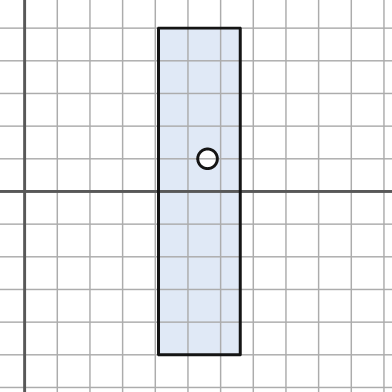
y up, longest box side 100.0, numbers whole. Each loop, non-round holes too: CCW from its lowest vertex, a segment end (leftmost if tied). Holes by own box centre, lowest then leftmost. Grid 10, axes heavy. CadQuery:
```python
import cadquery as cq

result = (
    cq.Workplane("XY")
    .moveTo(41.0, -50.0)
    .lineTo(66.0, -50.0)
    .lineTo(66.0, 50.0)
    .lineTo(41.0, 50.0)
    .close()
    .moveTo(56.0, 10.0)
    .circle(3.0)
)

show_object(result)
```